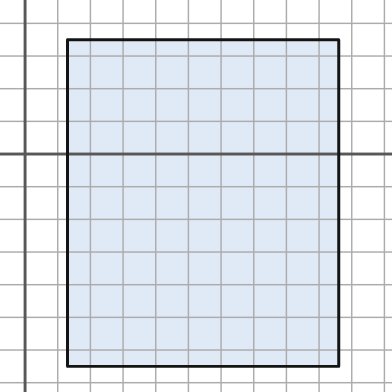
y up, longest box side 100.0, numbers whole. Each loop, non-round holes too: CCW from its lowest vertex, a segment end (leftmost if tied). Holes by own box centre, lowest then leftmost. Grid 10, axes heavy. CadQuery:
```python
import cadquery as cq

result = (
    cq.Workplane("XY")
    .moveTo(13.0, -65.0)
    .lineTo(96.0, -65.0)
    .lineTo(96.0, 35.0)
    .lineTo(13.0, 35.0)
    .close()
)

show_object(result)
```